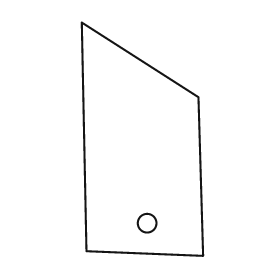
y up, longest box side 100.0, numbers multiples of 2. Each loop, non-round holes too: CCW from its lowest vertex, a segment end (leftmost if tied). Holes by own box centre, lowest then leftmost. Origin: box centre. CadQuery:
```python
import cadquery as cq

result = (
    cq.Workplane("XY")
    .moveTo(26.0, -50.0)
    .lineTo(24.0, 18.0)
    .lineTo(-26.0, 50.0)
    .lineTo(-24.0, -48.0)
    .close()
    .moveTo(2.0, -36.0)
    .circle(4.0)
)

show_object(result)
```